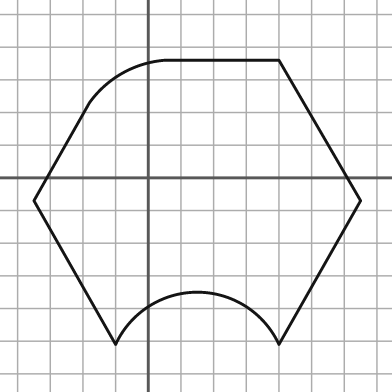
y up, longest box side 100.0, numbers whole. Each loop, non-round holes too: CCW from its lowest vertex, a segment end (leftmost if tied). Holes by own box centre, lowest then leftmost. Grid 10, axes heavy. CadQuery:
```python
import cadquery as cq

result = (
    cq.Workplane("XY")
    .moveTo(-10.0, -51.0)
    .threePointArc((15.0, -35.0), (40.0, -51.0))
    .lineTo(65.0, -7.0)
    .lineTo(40.0, 36.0)
    .lineTo(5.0, 36.0)
    .threePointArc((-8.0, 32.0), (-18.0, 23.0))
    .lineTo(-35.0, -7.0)
    .close()
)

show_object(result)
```